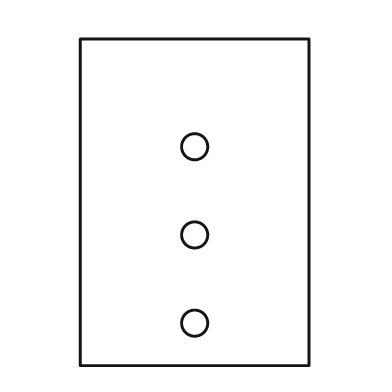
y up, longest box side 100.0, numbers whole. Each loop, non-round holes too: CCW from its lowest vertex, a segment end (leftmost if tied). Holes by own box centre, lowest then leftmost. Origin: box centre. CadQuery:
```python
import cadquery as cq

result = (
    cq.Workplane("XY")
    .moveTo(-35.0, -50.0)
    .lineTo(35.0, -50.0)
    .lineTo(35.0, 50.0)
    .lineTo(-35.0, 50.0)
    .close()
    .moveTo(0.0, -37.0)
    .circle(4.0)
    .moveTo(0.0, -10.0)
    .circle(4.0)
    .moveTo(0.0, 17.0)
    .circle(4.0)
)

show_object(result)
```